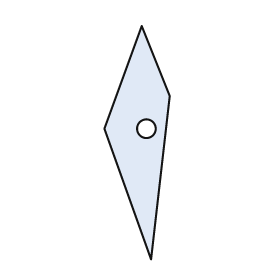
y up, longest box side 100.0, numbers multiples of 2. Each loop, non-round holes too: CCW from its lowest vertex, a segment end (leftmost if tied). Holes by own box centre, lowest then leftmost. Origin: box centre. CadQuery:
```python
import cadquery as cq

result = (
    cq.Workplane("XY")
    .moveTo(6.0, -50.0)
    .lineTo(14.0, 20.0)
    .lineTo(2.0, 50.0)
    .lineTo(-14.0, 6.0)
    .close()
    .moveTo(4.0, 6.0)
    .circle(4.0)
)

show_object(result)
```